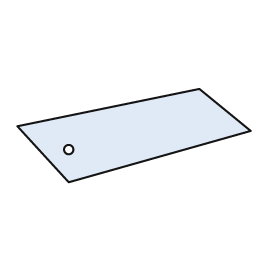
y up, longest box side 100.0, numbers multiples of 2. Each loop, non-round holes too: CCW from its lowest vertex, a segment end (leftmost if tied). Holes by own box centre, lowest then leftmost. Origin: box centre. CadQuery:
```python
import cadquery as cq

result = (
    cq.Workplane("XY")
    .moveTo(-28.0, -20.0)
    .lineTo(50.0, 2.0)
    .lineTo(28.0, 20.0)
    .lineTo(-50.0, 4.0)
    .close()
    .moveTo(-28.0, -6.0)
    .circle(2.0)
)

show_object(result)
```